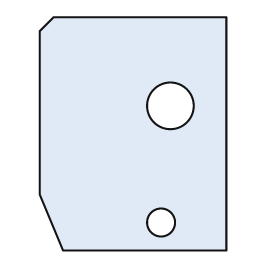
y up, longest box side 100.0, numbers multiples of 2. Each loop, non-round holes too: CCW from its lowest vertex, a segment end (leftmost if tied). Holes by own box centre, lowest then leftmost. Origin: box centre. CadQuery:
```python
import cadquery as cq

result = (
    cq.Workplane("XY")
    .moveTo(-30.0, -50.0)
    .lineTo(40.0, -50.0)
    .lineTo(40.0, 50.0)
    .lineTo(-34.0, 50.0)
    .lineTo(-40.0, 44.0)
    .lineTo(-40.0, -26.0)
    .close()
    .moveTo(12.0, -38.0)
    .circle(6.0)
    .moveTo(16.0, 12.0)
    .circle(10.0)
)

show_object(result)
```